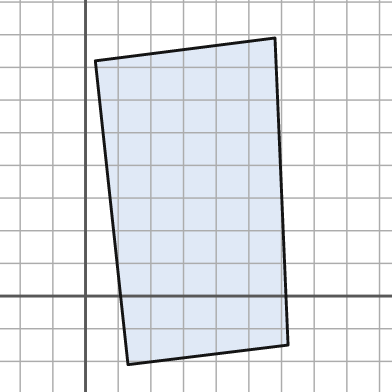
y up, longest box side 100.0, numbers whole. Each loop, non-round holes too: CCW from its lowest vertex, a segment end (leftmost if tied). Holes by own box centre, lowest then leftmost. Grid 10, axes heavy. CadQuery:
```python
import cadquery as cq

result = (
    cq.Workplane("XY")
    .moveTo(13.0, -21.0)
    .lineTo(62.0, -15.0)
    .lineTo(58.0, 79.0)
    .lineTo(3.0, 72.0)
    .close()
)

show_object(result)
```